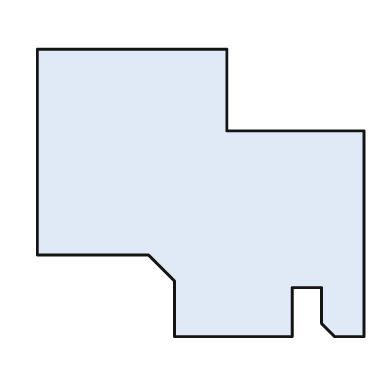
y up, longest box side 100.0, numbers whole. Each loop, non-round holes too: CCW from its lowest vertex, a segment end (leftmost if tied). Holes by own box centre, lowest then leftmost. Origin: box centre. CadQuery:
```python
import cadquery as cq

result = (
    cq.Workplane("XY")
    .moveTo(-8.0, -44.0)
    .lineTo(28.0, -44.0)
    .lineTo(28.0, -29.0)
    .lineTo(37.0, -29.0)
    .lineTo(37.0, -40.0)
    .lineTo(41.0, -44.0)
    .lineTo(50.0, -44.0)
    .lineTo(50.0, 19.0)
    .lineTo(8.0, 19.0)
    .lineTo(8.0, 44.0)
    .lineTo(-50.0, 44.0)
    .lineTo(-50.0, -19.0)
    .lineTo(-16.0, -19.0)
    .lineTo(-8.0, -27.0)
    .close()
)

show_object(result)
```